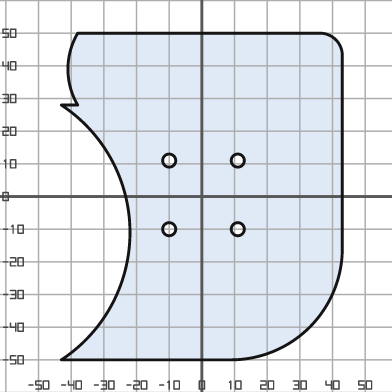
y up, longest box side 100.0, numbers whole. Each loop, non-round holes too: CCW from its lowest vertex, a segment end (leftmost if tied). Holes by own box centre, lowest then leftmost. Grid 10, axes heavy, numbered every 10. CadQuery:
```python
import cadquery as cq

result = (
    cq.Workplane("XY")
    .moveTo(-43.0, -50.0)
    .lineTo(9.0, -50.0)
    .threePointArc((33.0, -40.0), (43.0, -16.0))
    .lineTo(43.0, 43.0)
    .threePointArc((41.0, 48.0), (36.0, 50.0))
    .lineTo(-38.0, 50.0)
    .threePointArc((-41.0, 39.0), (-38.0, 28.0))
    .lineTo(-43.0, 28.0)
    .threePointArc((-22.0, -11.0), (-43.0, -50.0))
    .close()
    .moveTo(-10.0, -10.0)
    .circle(2.0)
    .moveTo(11.0, -10.0)
    .circle(2.0)
    .moveTo(-10.0, 11.0)
    .circle(2.0)
    .moveTo(11.0, 11.0)
    .circle(2.0)
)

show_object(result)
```